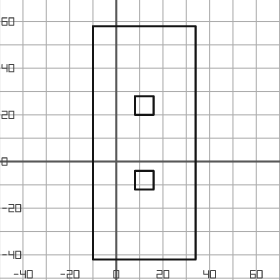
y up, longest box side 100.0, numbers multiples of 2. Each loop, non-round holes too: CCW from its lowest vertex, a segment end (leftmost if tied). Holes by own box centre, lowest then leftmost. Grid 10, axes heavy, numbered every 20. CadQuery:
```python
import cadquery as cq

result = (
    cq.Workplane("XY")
    .moveTo(-10.0, -42.0)
    .lineTo(34.0, -42.0)
    .lineTo(34.0, 58.0)
    .lineTo(-10.0, 58.0)
    .close()
    .moveTo(8.0, -12.0)
    .lineTo(16.0, -12.0)
    .lineTo(16.0, -4.0)
    .lineTo(8.0, -4.0)
    .close()
    .moveTo(8.0, 20.0)
    .lineTo(16.0, 20.0)
    .lineTo(16.0, 28.0)
    .lineTo(8.0, 28.0)
    .close()
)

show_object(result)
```